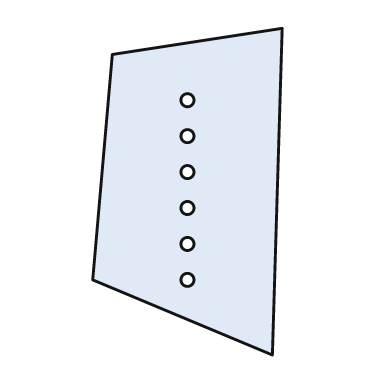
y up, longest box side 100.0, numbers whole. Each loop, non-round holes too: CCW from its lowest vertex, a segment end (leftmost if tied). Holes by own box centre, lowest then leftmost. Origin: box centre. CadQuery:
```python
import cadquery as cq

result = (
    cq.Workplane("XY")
    .moveTo(26.0, -50.0)
    .lineTo(29.0, 50.0)
    .lineTo(-23.0, 42.0)
    .lineTo(-29.0, -27.0)
    .close()
    .moveTo(0.0, -27.0)
    .circle(2.0)
    .moveTo(0.0, -16.0)
    .circle(2.0)
    .moveTo(0.0, -5.0)
    .circle(2.0)
    .moveTo(0.0, 6.0)
    .circle(2.0)
    .moveTo(0.0, 17.0)
    .circle(2.0)
    .moveTo(0.0, 28.0)
    .circle(2.0)
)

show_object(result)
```